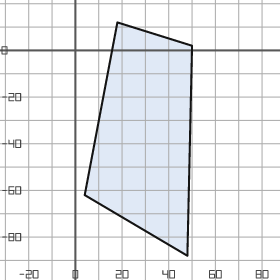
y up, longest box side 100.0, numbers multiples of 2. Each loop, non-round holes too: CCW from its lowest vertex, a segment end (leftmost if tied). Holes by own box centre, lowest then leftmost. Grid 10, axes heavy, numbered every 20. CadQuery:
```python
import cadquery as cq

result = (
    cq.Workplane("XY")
    .moveTo(48.0, -88.0)
    .lineTo(50.0, 2.0)
    .lineTo(18.0, 12.0)
    .lineTo(4.0, -62.0)
    .close()
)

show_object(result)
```